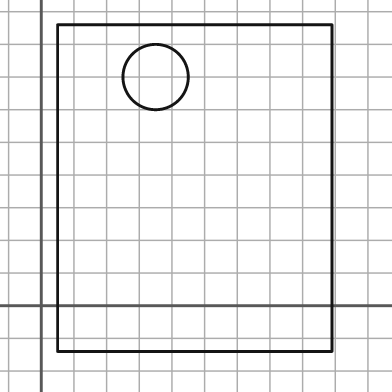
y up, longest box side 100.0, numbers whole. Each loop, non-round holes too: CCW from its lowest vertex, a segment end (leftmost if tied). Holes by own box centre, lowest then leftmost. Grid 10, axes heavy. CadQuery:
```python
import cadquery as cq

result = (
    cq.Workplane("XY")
    .moveTo(5.0, -14.0)
    .lineTo(89.0, -14.0)
    .lineTo(89.0, 86.0)
    .lineTo(5.0, 86.0)
    .close()
    .moveTo(35.0, 70.0)
    .circle(10.0)
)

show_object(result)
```